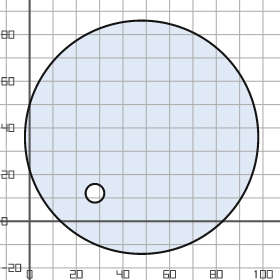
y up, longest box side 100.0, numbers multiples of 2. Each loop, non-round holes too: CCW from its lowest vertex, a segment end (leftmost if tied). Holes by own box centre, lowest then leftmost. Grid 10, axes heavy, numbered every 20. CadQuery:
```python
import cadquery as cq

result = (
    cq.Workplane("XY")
    .moveTo(48.0, 36.0)
    .circle(50.0)
    .moveTo(28.0, 12.0)
    .circle(4.0)
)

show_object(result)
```